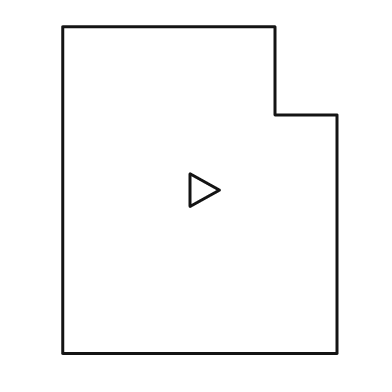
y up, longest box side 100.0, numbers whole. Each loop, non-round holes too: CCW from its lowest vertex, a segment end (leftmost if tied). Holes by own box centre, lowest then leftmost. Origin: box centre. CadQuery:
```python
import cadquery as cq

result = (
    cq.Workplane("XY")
    .moveTo(-42.0, -50.0)
    .lineTo(42.0, -50.0)
    .lineTo(42.0, 23.0)
    .lineTo(23.0, 23.0)
    .lineTo(23.0, 50.0)
    .lineTo(-42.0, 50.0)
    .close()
    .moveTo(-3.0, -5.0)
    .lineTo(6.0, 0.0)
    .lineTo(-3.0, 5.0)
    .close()
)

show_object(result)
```